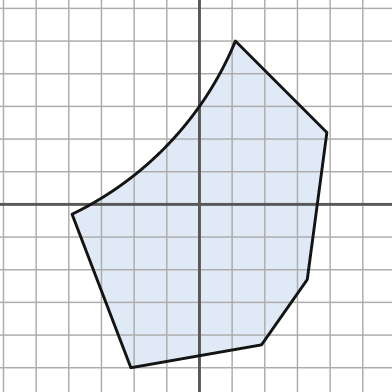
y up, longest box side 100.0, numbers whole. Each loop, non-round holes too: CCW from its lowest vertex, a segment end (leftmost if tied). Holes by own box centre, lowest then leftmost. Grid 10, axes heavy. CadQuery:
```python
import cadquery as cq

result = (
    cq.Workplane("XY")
    .moveTo(-21.0, -50.0)
    .lineTo(19.0, -43.0)
    .lineTo(33.0, -23.0)
    .lineTo(39.0, 22.0)
    .lineTo(11.0, 50.0)
    .threePointArc((-9.0, 19.0), (-39.0, -3.0))
    .close()
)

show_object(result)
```